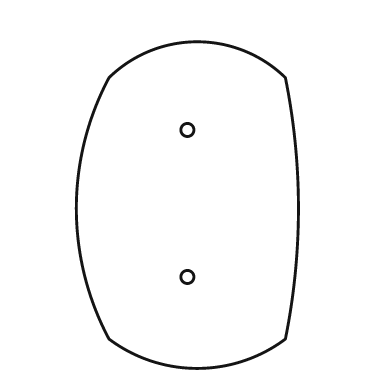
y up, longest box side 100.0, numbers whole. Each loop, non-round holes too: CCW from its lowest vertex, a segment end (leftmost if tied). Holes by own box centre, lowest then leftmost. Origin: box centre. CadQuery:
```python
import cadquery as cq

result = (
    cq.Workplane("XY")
    .moveTo(-24.0, -41.0)
    .threePointArc((3.0, -50.0), (30.0, -41.0))
    .threePointArc((34.0, -1.0), (30.0, 39.0))
    .threePointArc((3.0, 50.0), (-24.0, 39.0))
    .threePointArc((-34.0, -1.0), (-24.0, -41.0))
    .close()
    .moveTo(0.0, -22.0)
    .circle(2.0)
    .moveTo(0.0, 23.0)
    .circle(2.0)
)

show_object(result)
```